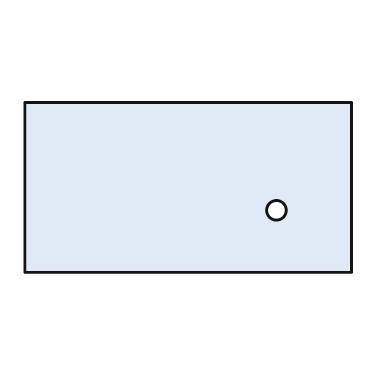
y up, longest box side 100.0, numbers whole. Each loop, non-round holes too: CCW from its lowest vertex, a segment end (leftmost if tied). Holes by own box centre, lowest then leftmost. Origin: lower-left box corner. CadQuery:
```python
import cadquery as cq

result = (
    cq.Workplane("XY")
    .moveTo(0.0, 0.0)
    .lineTo(100.0, 0.0)
    .lineTo(100.0, 52.0)
    .lineTo(0.0, 52.0)
    .close()
    .moveTo(77.0, 19.0)
    .circle(3.0)
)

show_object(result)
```